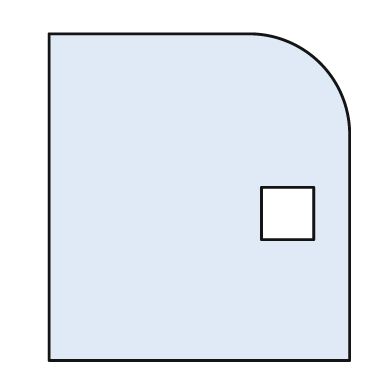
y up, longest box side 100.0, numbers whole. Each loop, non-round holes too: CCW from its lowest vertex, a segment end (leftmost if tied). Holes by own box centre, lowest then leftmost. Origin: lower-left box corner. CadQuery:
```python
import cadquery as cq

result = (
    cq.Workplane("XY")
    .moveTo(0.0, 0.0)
    .lineTo(92.0, 0.0)
    .lineTo(92.0, 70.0)
    .threePointArc((83.0, 91.0), (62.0, 100.0))
    .lineTo(0.0, 100.0)
    .close()
    .moveTo(65.0, 37.0)
    .lineTo(81.0, 37.0)
    .lineTo(81.0, 53.0)
    .lineTo(65.0, 53.0)
    .close()
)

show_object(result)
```